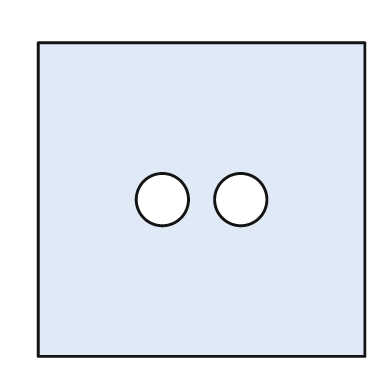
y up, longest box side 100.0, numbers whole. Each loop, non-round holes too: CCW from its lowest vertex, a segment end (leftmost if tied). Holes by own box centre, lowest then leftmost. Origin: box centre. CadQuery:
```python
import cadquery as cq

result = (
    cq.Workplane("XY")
    .moveTo(-50.0, -48.0)
    .lineTo(50.0, -48.0)
    .lineTo(50.0, 48.0)
    .lineTo(-50.0, 48.0)
    .close()
    .moveTo(-12.0, 0.0)
    .circle(8.0)
    .moveTo(12.0, 0.0)
    .circle(8.0)
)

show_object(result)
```